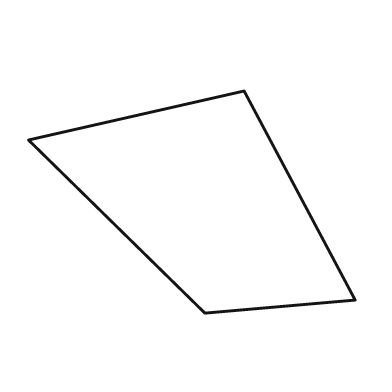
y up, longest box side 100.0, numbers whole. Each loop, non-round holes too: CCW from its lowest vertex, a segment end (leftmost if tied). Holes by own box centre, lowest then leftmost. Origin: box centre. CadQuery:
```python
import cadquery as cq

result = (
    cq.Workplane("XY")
    .moveTo(4.0, -34.0)
    .lineTo(50.0, -30.0)
    .lineTo(16.0, 34.0)
    .lineTo(-50.0, 19.0)
    .close()
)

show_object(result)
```